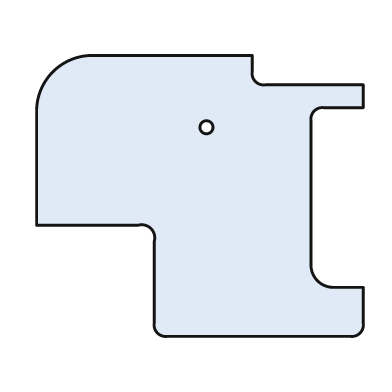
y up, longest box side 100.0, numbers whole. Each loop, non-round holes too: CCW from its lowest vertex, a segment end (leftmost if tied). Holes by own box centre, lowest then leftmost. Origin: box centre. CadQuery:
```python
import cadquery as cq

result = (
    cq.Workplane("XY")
    .moveTo(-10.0, -43.0)
    .lineTo(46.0, -43.0)
    .threePointArc((49.0, -42.0), (50.0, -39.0))
    .lineTo(50.0, -28.0)
    .lineTo(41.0, -28.0)
    .threePointArc((36.0, -26.0), (34.0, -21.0))
    .lineTo(34.0, 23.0)
    .threePointArc((35.0, 26.0), (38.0, 27.0))
    .lineTo(50.0, 27.0)
    .lineTo(50.0, 34.0)
    .lineTo(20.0, 34.0)
    .threePointArc((17.0, 35.0), (16.0, 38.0))
    .lineTo(16.0, 43.0)
    .lineTo(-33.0, 43.0)
    .threePointArc((-45.0, 38.0), (-50.0, 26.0))
    .lineTo(-50.0, -9.0)
    .lineTo(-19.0, -9.0)
    .threePointArc((-15.0, -10.0), (-14.0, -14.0))
    .lineTo(-14.0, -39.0)
    .threePointArc((-13.0, -42.0), (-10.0, -43.0))
    .close()
    .moveTo(2.0, 21.0)
    .circle(2.0)
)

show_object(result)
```